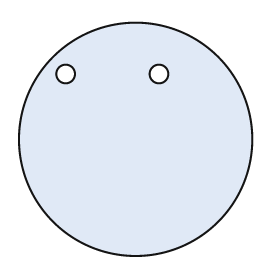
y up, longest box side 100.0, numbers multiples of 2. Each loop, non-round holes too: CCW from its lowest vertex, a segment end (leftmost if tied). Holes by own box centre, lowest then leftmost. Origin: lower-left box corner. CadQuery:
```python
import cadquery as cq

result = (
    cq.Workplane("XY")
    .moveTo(50.0, 50.0)
    .circle(50.0)
    .moveTo(20.0, 78.0)
    .circle(4.0)
    .moveTo(60.0, 78.0)
    .circle(4.0)
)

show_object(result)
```